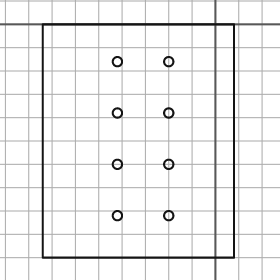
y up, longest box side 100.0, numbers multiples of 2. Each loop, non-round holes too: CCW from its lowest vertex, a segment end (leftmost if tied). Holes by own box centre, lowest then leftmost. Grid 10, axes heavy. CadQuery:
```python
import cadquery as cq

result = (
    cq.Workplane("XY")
    .moveTo(-74.0, -100.0)
    .lineTo(8.0, -100.0)
    .lineTo(8.0, 0.0)
    .lineTo(-74.0, 0.0)
    .close()
    .moveTo(-42.0, -82.0)
    .circle(2.0)
    .moveTo(-20.0, -82.0)
    .circle(2.0)
    .moveTo(-42.0, -60.0)
    .circle(2.0)
    .moveTo(-20.0, -60.0)
    .circle(2.0)
    .moveTo(-42.0, -38.0)
    .circle(2.0)
    .moveTo(-20.0, -38.0)
    .circle(2.0)
    .moveTo(-42.0, -16.0)
    .circle(2.0)
    .moveTo(-20.0, -16.0)
    .circle(2.0)
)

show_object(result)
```